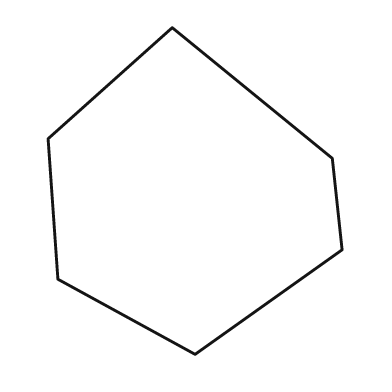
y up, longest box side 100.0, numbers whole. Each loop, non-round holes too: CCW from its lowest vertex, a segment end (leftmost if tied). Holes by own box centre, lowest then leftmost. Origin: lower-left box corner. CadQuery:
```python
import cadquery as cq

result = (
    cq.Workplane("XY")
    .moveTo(45.0, 0.0)
    .lineTo(90.0, 32.0)
    .lineTo(87.0, 60.0)
    .lineTo(38.0, 100.0)
    .lineTo(0.0, 66.0)
    .lineTo(3.0, 23.0)
    .close()
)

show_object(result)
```